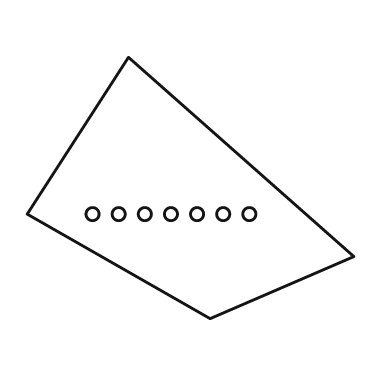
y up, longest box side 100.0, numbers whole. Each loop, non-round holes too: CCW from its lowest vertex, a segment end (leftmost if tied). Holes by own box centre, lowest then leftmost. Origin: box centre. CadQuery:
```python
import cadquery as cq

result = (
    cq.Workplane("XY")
    .moveTo(6.0, -40.0)
    .lineTo(50.0, -21.0)
    .lineTo(-19.0, 40.0)
    .lineTo(-50.0, -8.0)
    .close()
    .moveTo(-30.0, -8.0)
    .circle(2.0)
    .moveTo(-22.0, -8.0)
    .circle(2.0)
    .moveTo(-14.0, -8.0)
    .circle(2.0)
    .moveTo(-6.0, -8.0)
    .circle(2.0)
    .moveTo(2.0, -8.0)
    .circle(2.0)
    .moveTo(10.0, -8.0)
    .circle(2.0)
    .moveTo(18.0, -8.0)
    .circle(2.0)
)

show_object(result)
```